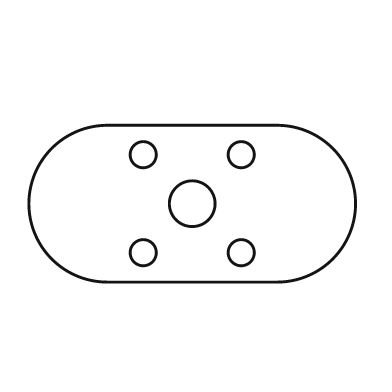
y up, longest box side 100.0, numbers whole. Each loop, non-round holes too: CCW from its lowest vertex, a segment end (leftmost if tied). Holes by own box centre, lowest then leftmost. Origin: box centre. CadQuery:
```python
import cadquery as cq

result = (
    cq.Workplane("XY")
    .moveTo(-26.0, -24.0)
    .lineTo(26.0, -24.0)
    .threePointArc((50.0, 0.0), (26.0, 24.0))
    .lineTo(-26.0, 24.0)
    .threePointArc((-50.0, 0.0), (-26.0, -24.0))
    .close()
    .moveTo(-15.0, -15.0)
    .circle(4.0)
    .moveTo(15.0, -15.0)
    .circle(4.0)
    .moveTo(0.0, 0.0)
    .circle(7.0)
    .moveTo(-15.0, 15.0)
    .circle(4.0)
    .moveTo(15.0, 15.0)
    .circle(4.0)
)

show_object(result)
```